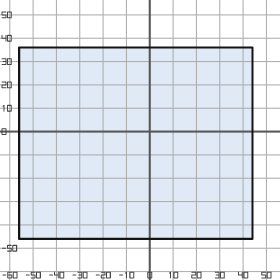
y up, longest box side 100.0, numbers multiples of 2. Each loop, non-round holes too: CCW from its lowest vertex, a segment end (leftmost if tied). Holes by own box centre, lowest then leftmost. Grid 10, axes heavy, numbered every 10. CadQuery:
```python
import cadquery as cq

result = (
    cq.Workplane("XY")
    .moveTo(-56.0, -46.0)
    .lineTo(44.0, -46.0)
    .lineTo(44.0, 36.0)
    .lineTo(-56.0, 36.0)
    .close()
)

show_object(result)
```